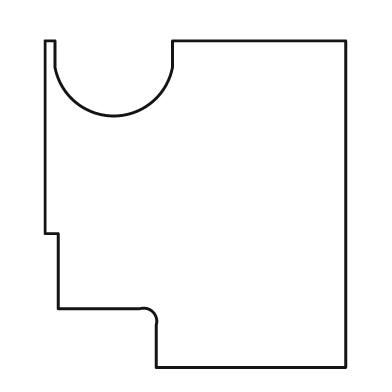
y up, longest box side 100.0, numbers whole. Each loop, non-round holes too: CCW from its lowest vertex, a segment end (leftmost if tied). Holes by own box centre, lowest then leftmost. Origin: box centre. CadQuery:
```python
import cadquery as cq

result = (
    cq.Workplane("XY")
    .moveTo(-12.0, -50.0)
    .lineTo(46.0, -50.0)
    .lineTo(46.0, 50.0)
    .lineTo(-7.0, 50.0)
    .lineTo(-7.0, 42.0)
    .threePointArc((-25.0, 27.0), (-43.0, 42.0))
    .lineTo(-43.0, 50.0)
    .lineTo(-46.0, 50.0)
    .lineTo(-46.0, -9.0)
    .lineTo(-42.0, -9.0)
    .lineTo(-42.0, -32.0)
    .lineTo(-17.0, -32.0)
    .threePointArc((-13.0, -33.0), (-12.0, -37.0))
    .close()
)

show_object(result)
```